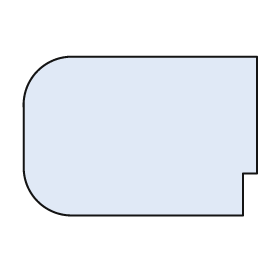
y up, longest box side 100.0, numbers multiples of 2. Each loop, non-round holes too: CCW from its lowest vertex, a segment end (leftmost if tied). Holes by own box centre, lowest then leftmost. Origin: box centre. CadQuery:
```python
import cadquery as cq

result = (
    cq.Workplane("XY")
    .moveTo(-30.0, -34.0)
    .lineTo(44.0, -34.0)
    .lineTo(44.0, -16.0)
    .lineTo(50.0, -16.0)
    .lineTo(50.0, 34.0)
    .lineTo(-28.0, 34.0)
    .threePointArc((-44.0, 28.0), (-50.0, 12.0))
    .lineTo(-50.0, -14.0)
    .threePointArc((-44.0, -28.0), (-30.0, -34.0))
    .close()
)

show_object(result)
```